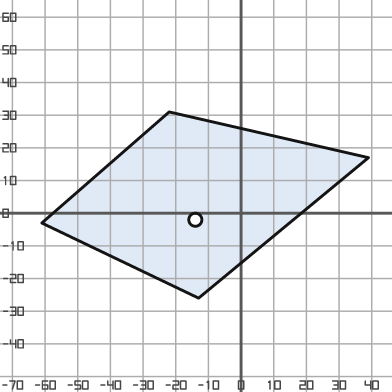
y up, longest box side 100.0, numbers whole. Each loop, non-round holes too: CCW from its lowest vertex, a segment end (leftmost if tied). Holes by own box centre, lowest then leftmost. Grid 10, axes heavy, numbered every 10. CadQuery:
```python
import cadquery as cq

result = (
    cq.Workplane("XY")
    .moveTo(-13.0, -26.0)
    .lineTo(39.0, 17.0)
    .lineTo(-22.0, 31.0)
    .lineTo(-61.0, -3.0)
    .close()
    .moveTo(-14.0, -2.0)
    .circle(2.0)
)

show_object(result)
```